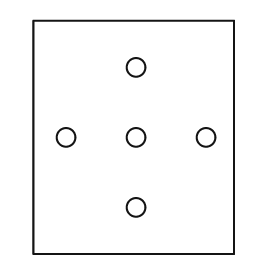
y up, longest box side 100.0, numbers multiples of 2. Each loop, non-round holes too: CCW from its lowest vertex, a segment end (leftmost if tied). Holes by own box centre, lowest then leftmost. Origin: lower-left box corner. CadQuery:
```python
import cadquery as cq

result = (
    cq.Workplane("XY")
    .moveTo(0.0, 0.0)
    .lineTo(86.0, 0.0)
    .lineTo(86.0, 100.0)
    .lineTo(0.0, 100.0)
    .close()
    .moveTo(44.0, 20.0)
    .circle(4.0)
    .moveTo(14.0, 50.0)
    .circle(4.0)
    .moveTo(44.0, 50.0)
    .circle(4.0)
    .moveTo(74.0, 50.0)
    .circle(4.0)
    .moveTo(44.0, 80.0)
    .circle(4.0)
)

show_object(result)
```